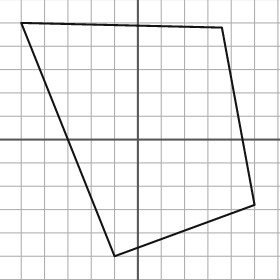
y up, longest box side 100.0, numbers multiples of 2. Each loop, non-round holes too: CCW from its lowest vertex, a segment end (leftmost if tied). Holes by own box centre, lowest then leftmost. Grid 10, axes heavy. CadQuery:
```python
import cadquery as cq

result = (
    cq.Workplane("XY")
    .moveTo(-10.0, -50.0)
    .lineTo(50.0, -28.0)
    .lineTo(36.0, 48.0)
    .lineTo(-50.0, 50.0)
    .close()
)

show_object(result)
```